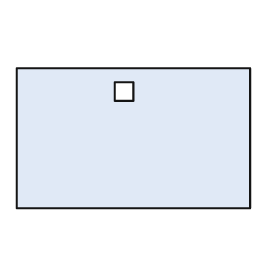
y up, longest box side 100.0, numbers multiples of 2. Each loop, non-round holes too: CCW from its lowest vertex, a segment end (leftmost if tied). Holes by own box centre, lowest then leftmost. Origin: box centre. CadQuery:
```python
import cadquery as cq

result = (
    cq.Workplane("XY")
    .moveTo(-50.0, -30.0)
    .lineTo(50.0, -30.0)
    .lineTo(50.0, 30.0)
    .lineTo(-50.0, 30.0)
    .close()
    .moveTo(-8.0, 16.0)
    .lineTo(0.0, 16.0)
    .lineTo(0.0, 24.0)
    .lineTo(-8.0, 24.0)
    .close()
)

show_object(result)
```